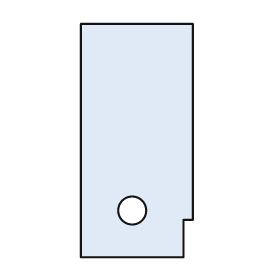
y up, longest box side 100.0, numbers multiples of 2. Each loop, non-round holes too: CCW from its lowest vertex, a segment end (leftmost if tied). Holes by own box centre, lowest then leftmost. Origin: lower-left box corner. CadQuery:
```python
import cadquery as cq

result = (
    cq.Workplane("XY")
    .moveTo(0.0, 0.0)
    .lineTo(44.0, 0.0)
    .lineTo(44.0, 16.0)
    .lineTo(48.0, 16.0)
    .lineTo(48.0, 100.0)
    .lineTo(0.0, 100.0)
    .close()
    .moveTo(22.0, 20.0)
    .circle(6.0)
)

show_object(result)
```